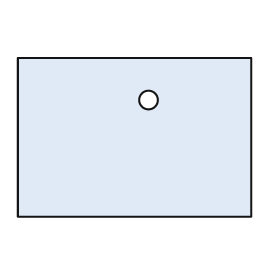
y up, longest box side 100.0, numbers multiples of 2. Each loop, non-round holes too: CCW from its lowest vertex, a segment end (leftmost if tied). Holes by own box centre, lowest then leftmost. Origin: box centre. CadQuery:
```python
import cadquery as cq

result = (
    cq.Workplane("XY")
    .moveTo(-50.0, -34.0)
    .lineTo(50.0, -34.0)
    .lineTo(50.0, 34.0)
    .lineTo(-50.0, 34.0)
    .close()
    .moveTo(6.0, 16.0)
    .circle(4.0)
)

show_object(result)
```